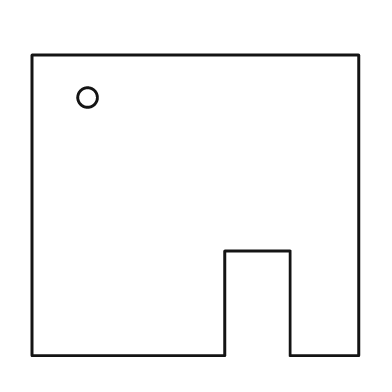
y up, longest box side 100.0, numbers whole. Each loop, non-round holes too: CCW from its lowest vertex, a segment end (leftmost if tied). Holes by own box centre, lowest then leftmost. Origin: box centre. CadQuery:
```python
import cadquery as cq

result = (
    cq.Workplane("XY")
    .moveTo(-50.0, -46.0)
    .lineTo(9.0, -46.0)
    .lineTo(9.0, -14.0)
    .lineTo(29.0, -14.0)
    .lineTo(29.0, -46.0)
    .lineTo(50.0, -46.0)
    .lineTo(50.0, 46.0)
    .lineTo(-50.0, 46.0)
    .close()
    .moveTo(-33.0, 33.0)
    .circle(3.0)
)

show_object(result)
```